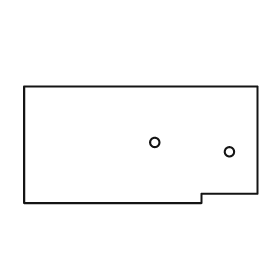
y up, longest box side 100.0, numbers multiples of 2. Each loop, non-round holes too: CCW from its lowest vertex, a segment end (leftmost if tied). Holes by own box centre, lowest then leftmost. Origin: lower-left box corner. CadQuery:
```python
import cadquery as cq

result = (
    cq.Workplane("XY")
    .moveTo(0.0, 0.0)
    .lineTo(76.0, 0.0)
    .lineTo(76.0, 4.0)
    .lineTo(100.0, 4.0)
    .lineTo(100.0, 50.0)
    .lineTo(0.0, 50.0)
    .close()
    .moveTo(88.0, 22.0)
    .circle(2.0)
    .moveTo(56.0, 26.0)
    .circle(2.0)
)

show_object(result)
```